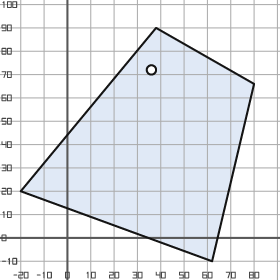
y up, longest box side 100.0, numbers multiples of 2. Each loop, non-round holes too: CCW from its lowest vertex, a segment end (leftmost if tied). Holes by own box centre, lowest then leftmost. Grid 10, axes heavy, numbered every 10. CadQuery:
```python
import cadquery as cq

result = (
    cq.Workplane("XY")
    .moveTo(62.0, -10.0)
    .lineTo(80.0, 66.0)
    .lineTo(38.0, 90.0)
    .lineTo(-20.0, 20.0)
    .close()
    .moveTo(36.0, 72.0)
    .circle(2.0)
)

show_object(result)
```